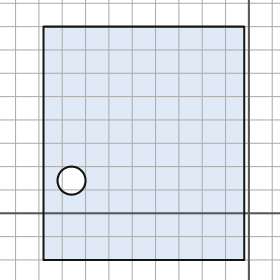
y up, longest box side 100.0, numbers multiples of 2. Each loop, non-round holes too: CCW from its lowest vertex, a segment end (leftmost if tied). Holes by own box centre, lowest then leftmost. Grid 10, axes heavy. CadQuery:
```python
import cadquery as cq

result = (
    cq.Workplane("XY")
    .moveTo(-88.0, -20.0)
    .lineTo(-2.0, -20.0)
    .lineTo(-2.0, 80.0)
    .lineTo(-88.0, 80.0)
    .close()
    .moveTo(-76.0, 14.0)
    .circle(6.0)
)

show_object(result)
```